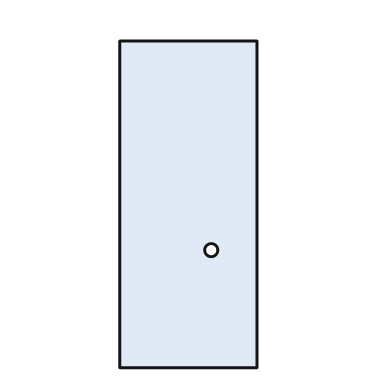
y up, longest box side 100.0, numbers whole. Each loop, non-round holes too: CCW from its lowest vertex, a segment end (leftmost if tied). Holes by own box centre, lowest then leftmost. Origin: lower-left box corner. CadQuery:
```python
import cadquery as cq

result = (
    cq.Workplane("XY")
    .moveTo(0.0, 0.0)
    .lineTo(42.0, 0.0)
    .lineTo(42.0, 100.0)
    .lineTo(0.0, 100.0)
    .close()
    .moveTo(28.0, 36.0)
    .circle(2.0)
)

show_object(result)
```